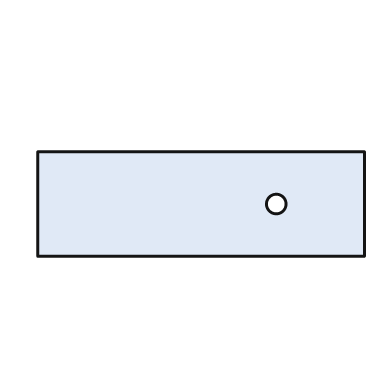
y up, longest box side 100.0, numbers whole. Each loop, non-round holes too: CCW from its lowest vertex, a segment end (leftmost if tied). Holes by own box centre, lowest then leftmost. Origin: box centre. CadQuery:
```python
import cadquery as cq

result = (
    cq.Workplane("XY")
    .moveTo(-50.0, -16.0)
    .lineTo(50.0, -16.0)
    .lineTo(50.0, 16.0)
    .lineTo(-50.0, 16.0)
    .close()
    .moveTo(23.0, 0.0)
    .circle(3.0)
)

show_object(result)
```